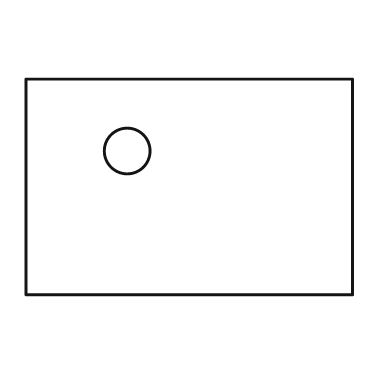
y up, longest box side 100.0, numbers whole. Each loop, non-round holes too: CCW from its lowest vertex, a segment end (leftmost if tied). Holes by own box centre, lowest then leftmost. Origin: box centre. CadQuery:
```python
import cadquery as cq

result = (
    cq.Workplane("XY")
    .moveTo(-50.0, -33.0)
    .lineTo(50.0, -33.0)
    .lineTo(50.0, 33.0)
    .lineTo(-50.0, 33.0)
    .close()
    .moveTo(-19.0, 11.0)
    .circle(7.0)
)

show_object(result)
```